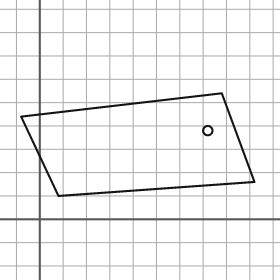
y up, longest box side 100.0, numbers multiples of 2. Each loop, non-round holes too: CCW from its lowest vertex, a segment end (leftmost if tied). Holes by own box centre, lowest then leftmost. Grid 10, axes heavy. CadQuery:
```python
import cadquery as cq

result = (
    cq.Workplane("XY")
    .moveTo(8.0, 10.0)
    .lineTo(92.0, 16.0)
    .lineTo(78.0, 54.0)
    .lineTo(-8.0, 44.0)
    .close()
    .moveTo(72.0, 38.0)
    .circle(2.0)
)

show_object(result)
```